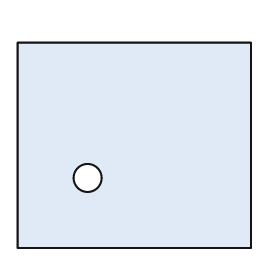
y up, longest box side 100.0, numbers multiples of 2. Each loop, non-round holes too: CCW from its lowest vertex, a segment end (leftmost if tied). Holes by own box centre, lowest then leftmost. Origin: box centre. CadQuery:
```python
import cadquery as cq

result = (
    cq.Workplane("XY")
    .moveTo(-50.0, -44.0)
    .lineTo(50.0, -44.0)
    .lineTo(50.0, 44.0)
    .lineTo(-50.0, 44.0)
    .close()
    .moveTo(-20.0, -14.0)
    .circle(6.0)
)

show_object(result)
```